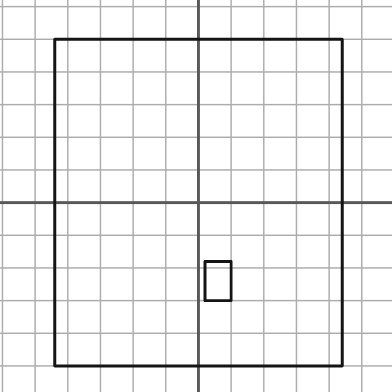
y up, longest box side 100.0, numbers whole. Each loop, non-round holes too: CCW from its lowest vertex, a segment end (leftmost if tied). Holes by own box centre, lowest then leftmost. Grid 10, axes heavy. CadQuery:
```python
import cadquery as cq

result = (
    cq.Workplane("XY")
    .moveTo(-44.0, -50.0)
    .lineTo(44.0, -50.0)
    .lineTo(44.0, 50.0)
    .lineTo(-44.0, 50.0)
    .close()
    .moveTo(2.0, -30.0)
    .lineTo(10.0, -30.0)
    .lineTo(10.0, -18.0)
    .lineTo(2.0, -18.0)
    .close()
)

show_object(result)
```